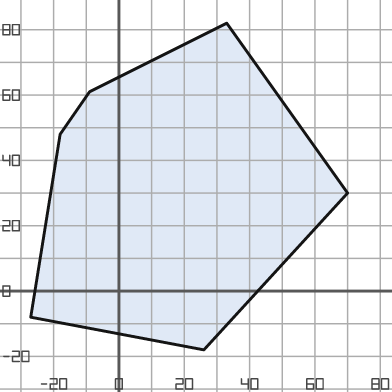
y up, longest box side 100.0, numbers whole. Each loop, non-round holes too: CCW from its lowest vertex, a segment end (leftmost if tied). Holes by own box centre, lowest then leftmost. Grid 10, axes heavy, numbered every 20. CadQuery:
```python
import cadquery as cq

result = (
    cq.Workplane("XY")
    .moveTo(26.0, -18.0)
    .lineTo(70.0, 30.0)
    .lineTo(33.0, 82.0)
    .lineTo(-9.0, 61.0)
    .lineTo(-18.0, 48.0)
    .lineTo(-27.0, -8.0)
    .close()
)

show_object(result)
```